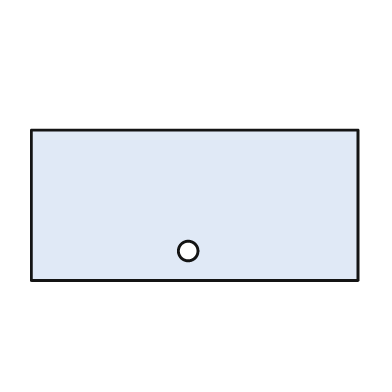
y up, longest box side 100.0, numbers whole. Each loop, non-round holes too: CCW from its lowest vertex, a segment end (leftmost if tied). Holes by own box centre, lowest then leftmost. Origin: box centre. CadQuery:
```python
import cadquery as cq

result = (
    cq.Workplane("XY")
    .moveTo(-50.0, -23.0)
    .lineTo(50.0, -23.0)
    .lineTo(50.0, 23.0)
    .lineTo(-50.0, 23.0)
    .close()
    .moveTo(-2.0, -14.0)
    .circle(3.0)
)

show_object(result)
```